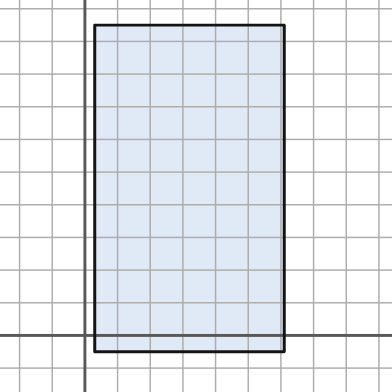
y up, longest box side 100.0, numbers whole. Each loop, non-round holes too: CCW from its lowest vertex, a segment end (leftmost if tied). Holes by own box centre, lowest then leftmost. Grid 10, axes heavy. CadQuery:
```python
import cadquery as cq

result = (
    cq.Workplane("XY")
    .moveTo(3.0, -5.0)
    .lineTo(61.0, -5.0)
    .lineTo(61.0, 95.0)
    .lineTo(3.0, 95.0)
    .close()
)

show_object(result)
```